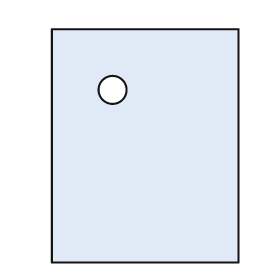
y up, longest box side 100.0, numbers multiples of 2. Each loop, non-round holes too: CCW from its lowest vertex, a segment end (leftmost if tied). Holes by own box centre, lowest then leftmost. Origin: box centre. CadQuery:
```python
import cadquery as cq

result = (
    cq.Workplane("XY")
    .moveTo(-40.0, -50.0)
    .lineTo(40.0, -50.0)
    .lineTo(40.0, 50.0)
    .lineTo(-40.0, 50.0)
    .close()
    .moveTo(-14.0, 24.0)
    .circle(6.0)
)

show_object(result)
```